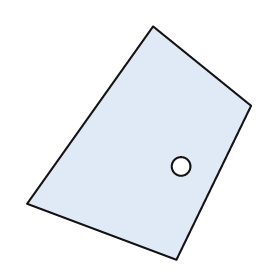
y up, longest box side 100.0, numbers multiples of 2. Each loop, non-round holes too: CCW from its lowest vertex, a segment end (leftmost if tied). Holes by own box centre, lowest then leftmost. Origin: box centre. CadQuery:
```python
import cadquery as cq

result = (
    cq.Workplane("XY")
    .moveTo(16.0, -50.0)
    .lineTo(48.0, 16.0)
    .lineTo(6.0, 50.0)
    .lineTo(-48.0, -26.0)
    .close()
    .moveTo(18.0, -10.0)
    .circle(4.0)
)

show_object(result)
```